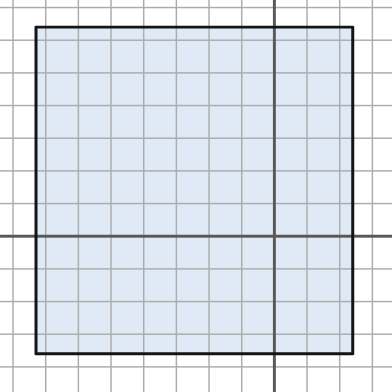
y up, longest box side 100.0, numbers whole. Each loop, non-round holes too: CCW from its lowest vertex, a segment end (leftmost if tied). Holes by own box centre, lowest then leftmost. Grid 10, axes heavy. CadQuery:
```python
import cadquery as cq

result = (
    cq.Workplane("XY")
    .moveTo(-73.0, -36.0)
    .lineTo(24.0, -36.0)
    .lineTo(24.0, 64.0)
    .lineTo(-73.0, 64.0)
    .close()
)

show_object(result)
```